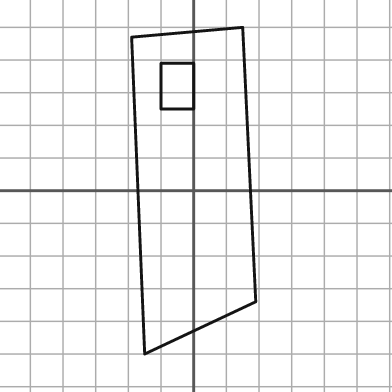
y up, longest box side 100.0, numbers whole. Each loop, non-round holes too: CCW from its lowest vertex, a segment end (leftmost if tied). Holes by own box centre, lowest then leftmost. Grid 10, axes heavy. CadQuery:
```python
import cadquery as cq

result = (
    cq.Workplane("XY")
    .moveTo(-15.0, -50.0)
    .lineTo(19.0, -34.0)
    .lineTo(15.0, 50.0)
    .lineTo(-19.0, 47.0)
    .close()
    .moveTo(-10.0, 25.0)
    .lineTo(0.0, 25.0)
    .lineTo(0.0, 39.0)
    .lineTo(-10.0, 39.0)
    .close()
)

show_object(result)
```